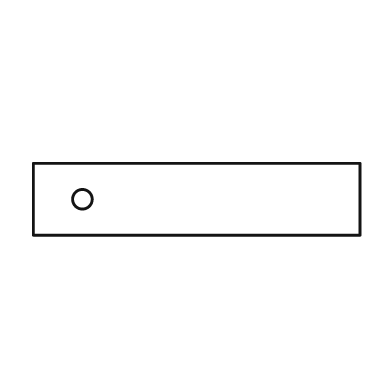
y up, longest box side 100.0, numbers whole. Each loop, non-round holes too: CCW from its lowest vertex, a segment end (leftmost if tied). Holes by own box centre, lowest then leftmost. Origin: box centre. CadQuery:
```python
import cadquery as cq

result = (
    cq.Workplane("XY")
    .moveTo(-50.0, -11.0)
    .lineTo(50.0, -11.0)
    .lineTo(50.0, 11.0)
    .lineTo(-50.0, 11.0)
    .close()
    .moveTo(-35.0, 0.0)
    .circle(3.0)
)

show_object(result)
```